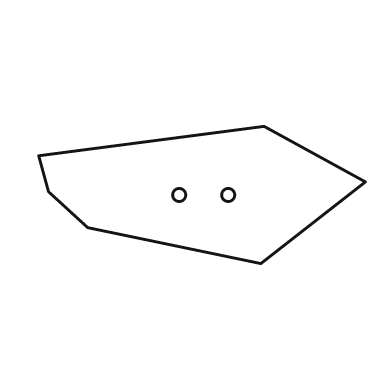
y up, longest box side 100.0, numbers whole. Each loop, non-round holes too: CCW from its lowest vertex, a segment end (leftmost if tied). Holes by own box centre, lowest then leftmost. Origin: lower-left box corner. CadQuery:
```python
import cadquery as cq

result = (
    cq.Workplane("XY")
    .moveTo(68.0, 0.0)
    .lineTo(100.0, 25.0)
    .lineTo(69.0, 42.0)
    .lineTo(0.0, 33.0)
    .lineTo(3.0, 22.0)
    .lineTo(15.0, 11.0)
    .close()
    .moveTo(43.0, 21.0)
    .circle(2.0)
    .moveTo(58.0, 21.0)
    .circle(2.0)
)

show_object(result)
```